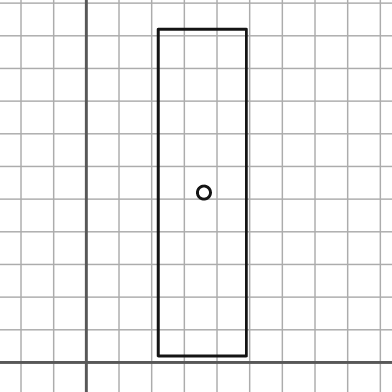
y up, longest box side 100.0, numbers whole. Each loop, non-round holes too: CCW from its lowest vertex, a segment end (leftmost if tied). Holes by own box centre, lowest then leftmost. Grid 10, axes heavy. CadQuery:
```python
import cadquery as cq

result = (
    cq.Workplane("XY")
    .moveTo(22.0, 2.0)
    .lineTo(49.0, 2.0)
    .lineTo(49.0, 102.0)
    .lineTo(22.0, 102.0)
    .close()
    .moveTo(36.0, 52.0)
    .circle(2.0)
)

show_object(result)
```